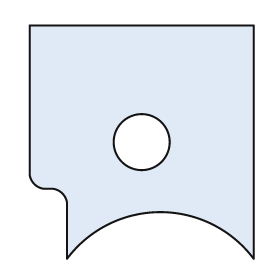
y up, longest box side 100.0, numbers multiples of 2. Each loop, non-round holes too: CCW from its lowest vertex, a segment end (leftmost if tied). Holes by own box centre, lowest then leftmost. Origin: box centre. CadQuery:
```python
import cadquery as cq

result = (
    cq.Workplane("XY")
    .moveTo(-32.0, -50.0)
    .threePointArc((8.0, -30.0), (48.0, -50.0))
    .lineTo(48.0, 50.0)
    .lineTo(-48.0, 50.0)
    .lineTo(-48.0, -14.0)
    .threePointArc((-46.0, -18.0), (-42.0, -20.0))
    .lineTo(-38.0, -20.0)
    .threePointArc((-34.0, -22.0), (-32.0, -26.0))
    .close()
    .moveTo(0.0, 0.0)
    .circle(12.0)
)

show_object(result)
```